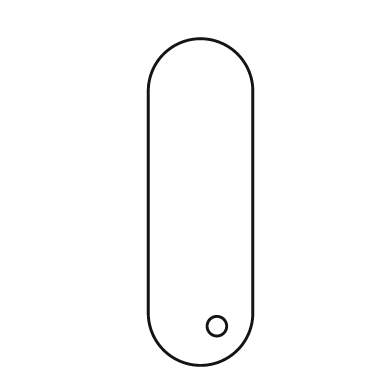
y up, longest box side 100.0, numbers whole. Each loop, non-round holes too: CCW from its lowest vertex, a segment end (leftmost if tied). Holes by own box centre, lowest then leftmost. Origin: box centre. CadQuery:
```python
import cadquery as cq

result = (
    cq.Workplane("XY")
    .moveTo(-16.0, -34.0)
    .threePointArc((0.0, -50.0), (16.0, -34.0))
    .lineTo(16.0, 34.0)
    .threePointArc((0.0, 50.0), (-16.0, 34.0))
    .close()
    .moveTo(5.0, -38.0)
    .circle(3.0)
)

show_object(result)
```